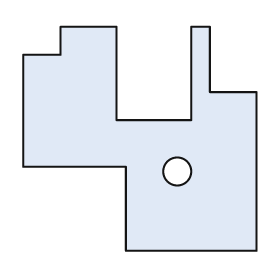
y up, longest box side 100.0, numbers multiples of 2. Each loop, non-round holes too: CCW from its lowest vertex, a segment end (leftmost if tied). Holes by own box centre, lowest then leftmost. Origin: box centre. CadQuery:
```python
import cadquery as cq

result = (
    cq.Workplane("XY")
    .moveTo(-6.0, -48.0)
    .lineTo(50.0, -48.0)
    .lineTo(50.0, 20.0)
    .lineTo(30.0, 20.0)
    .lineTo(30.0, 48.0)
    .lineTo(22.0, 48.0)
    .lineTo(22.0, 8.0)
    .lineTo(-10.0, 8.0)
    .lineTo(-10.0, 48.0)
    .lineTo(-34.0, 48.0)
    .lineTo(-34.0, 36.0)
    .lineTo(-50.0, 36.0)
    .lineTo(-50.0, -12.0)
    .lineTo(-6.0, -12.0)
    .close()
    .moveTo(16.0, -14.0)
    .circle(6.0)
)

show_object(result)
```